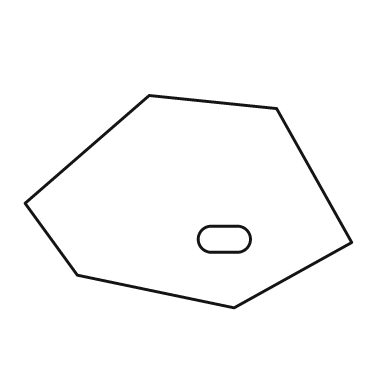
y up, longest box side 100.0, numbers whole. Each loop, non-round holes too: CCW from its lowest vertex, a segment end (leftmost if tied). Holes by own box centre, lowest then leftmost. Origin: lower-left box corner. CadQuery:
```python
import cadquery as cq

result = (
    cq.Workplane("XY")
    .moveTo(64.0, 0.0)
    .lineTo(100.0, 20.0)
    .lineTo(77.0, 61.0)
    .lineTo(38.0, 65.0)
    .lineTo(0.0, 32.0)
    .lineTo(16.0, 10.0)
    .close()
    .moveTo(57.0, 17.0)
    .lineTo(65.0, 17.0)
    .threePointArc((69.0, 21.0), (65.0, 25.0))
    .lineTo(57.0, 25.0)
    .threePointArc((53.0, 21.0), (57.0, 17.0))
    .close()
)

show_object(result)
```